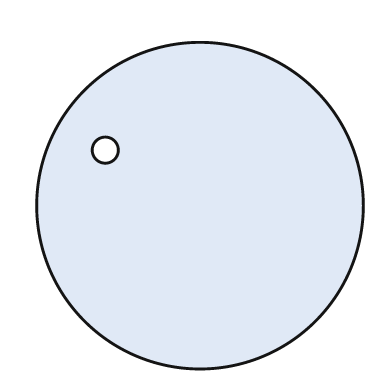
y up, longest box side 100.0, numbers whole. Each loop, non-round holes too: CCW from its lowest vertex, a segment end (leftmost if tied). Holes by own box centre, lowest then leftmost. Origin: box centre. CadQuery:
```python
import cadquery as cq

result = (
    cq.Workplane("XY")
    .moveTo(0.0, 0.0)
    .circle(50.0)
    .moveTo(-29.0, 17.0)
    .circle(4.0)
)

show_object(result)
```